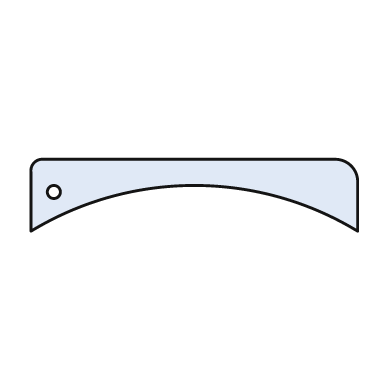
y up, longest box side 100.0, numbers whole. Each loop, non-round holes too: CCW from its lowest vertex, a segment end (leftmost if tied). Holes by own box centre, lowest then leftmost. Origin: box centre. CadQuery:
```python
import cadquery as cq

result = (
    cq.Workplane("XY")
    .moveTo(-50.0, -11.0)
    .threePointArc((0.0, 3.0), (50.0, -11.0))
    .lineTo(50.0, 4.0)
    .threePointArc((48.0, 9.0), (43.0, 11.0))
    .lineTo(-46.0, 11.0)
    .threePointArc((-49.0, 10.0), (-50.0, 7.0))
    .close()
    .moveTo(-43.0, 1.0)
    .circle(2.0)
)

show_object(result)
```